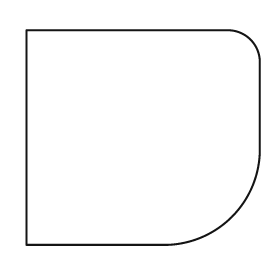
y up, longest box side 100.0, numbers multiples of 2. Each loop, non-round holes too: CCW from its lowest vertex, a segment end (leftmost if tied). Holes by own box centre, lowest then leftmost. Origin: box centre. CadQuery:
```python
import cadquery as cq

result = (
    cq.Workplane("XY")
    .moveTo(-50.0, -46.0)
    .lineTo(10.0, -46.0)
    .threePointArc((38.0, -34.0), (50.0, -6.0))
    .lineTo(50.0, 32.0)
    .threePointArc((46.0, 42.0), (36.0, 46.0))
    .lineTo(-50.0, 46.0)
    .close()
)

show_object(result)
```